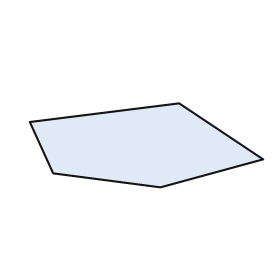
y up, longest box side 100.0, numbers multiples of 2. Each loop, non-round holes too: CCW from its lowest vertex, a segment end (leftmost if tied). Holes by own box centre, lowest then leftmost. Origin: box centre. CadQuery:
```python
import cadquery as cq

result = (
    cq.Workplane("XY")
    .moveTo(6.0, -18.0)
    .lineTo(50.0, -6.0)
    .lineTo(14.0, 18.0)
    .lineTo(-50.0, 10.0)
    .lineTo(-40.0, -12.0)
    .close()
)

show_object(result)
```